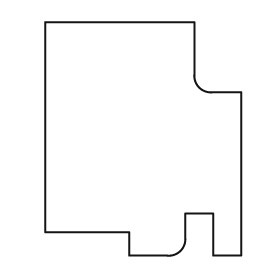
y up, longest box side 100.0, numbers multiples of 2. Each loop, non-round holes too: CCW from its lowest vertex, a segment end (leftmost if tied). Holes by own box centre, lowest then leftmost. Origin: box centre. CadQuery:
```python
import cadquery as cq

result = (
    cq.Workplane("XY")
    .moveTo(-6.0, -50.0)
    .lineTo(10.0, -50.0)
    .threePointArc((16.0, -48.0), (18.0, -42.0))
    .lineTo(18.0, -32.0)
    .lineTo(30.0, -32.0)
    .lineTo(30.0, -50.0)
    .lineTo(42.0, -50.0)
    .lineTo(42.0, 20.0)
    .lineTo(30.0, 20.0)
    .threePointArc((24.0, 22.0), (22.0, 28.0))
    .lineTo(22.0, 50.0)
    .lineTo(-42.0, 50.0)
    .lineTo(-42.0, -40.0)
    .lineTo(-6.0, -40.0)
    .close()
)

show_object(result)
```